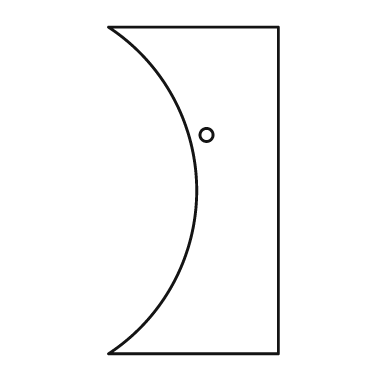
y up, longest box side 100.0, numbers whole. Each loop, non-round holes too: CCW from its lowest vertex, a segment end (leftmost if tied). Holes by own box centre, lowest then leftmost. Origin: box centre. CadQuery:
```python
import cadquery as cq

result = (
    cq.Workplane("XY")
    .moveTo(-26.0, -50.0)
    .lineTo(26.0, -50.0)
    .lineTo(26.0, 50.0)
    .lineTo(-26.0, 50.0)
    .threePointArc((1.0, 0.0), (-26.0, -50.0))
    .close()
    .moveTo(4.0, 17.0)
    .circle(2.0)
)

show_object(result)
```